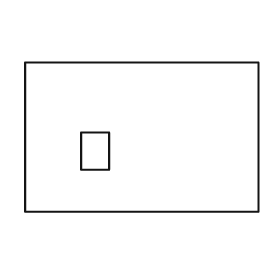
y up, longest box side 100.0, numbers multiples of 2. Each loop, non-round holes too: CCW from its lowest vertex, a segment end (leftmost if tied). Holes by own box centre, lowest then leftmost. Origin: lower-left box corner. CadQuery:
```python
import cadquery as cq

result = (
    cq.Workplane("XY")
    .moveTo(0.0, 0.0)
    .lineTo(100.0, 0.0)
    .lineTo(100.0, 64.0)
    .lineTo(0.0, 64.0)
    .close()
    .moveTo(24.0, 18.0)
    .lineTo(36.0, 18.0)
    .lineTo(36.0, 34.0)
    .lineTo(24.0, 34.0)
    .close()
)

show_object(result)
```